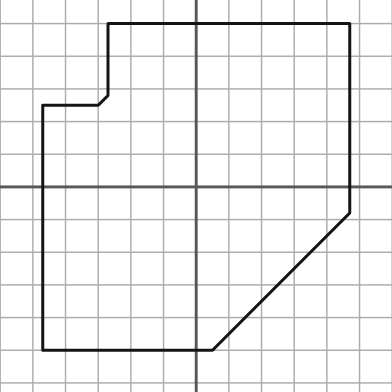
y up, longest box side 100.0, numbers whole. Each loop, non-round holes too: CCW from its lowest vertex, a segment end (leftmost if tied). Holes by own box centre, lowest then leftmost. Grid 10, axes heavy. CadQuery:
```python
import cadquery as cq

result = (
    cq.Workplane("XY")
    .moveTo(-47.0, -50.0)
    .lineTo(5.0, -50.0)
    .lineTo(47.0, -8.0)
    .lineTo(47.0, 50.0)
    .lineTo(-27.0, 50.0)
    .lineTo(-27.0, 28.0)
    .lineTo(-30.0, 25.0)
    .lineTo(-47.0, 25.0)
    .close()
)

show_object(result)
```